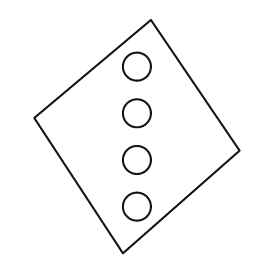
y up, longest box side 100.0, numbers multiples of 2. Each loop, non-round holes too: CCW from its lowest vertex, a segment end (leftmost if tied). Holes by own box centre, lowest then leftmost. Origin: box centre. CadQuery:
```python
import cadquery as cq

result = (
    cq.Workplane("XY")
    .moveTo(-6.0, -50.0)
    .lineTo(44.0, -6.0)
    .lineTo(6.0, 50.0)
    .lineTo(-44.0, 8.0)
    .close()
    .moveTo(0.0, -30.0)
    .circle(6.0)
    .moveTo(0.0, -10.0)
    .circle(6.0)
    .moveTo(0.0, 10.0)
    .circle(6.0)
    .moveTo(0.0, 30.0)
    .circle(6.0)
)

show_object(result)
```